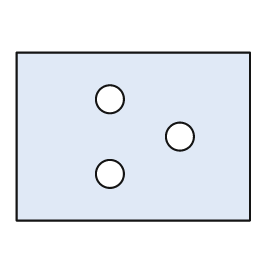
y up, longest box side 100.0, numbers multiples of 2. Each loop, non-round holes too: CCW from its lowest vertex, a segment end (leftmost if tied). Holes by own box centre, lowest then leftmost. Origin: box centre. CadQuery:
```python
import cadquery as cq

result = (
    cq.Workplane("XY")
    .moveTo(-50.0, -36.0)
    .lineTo(50.0, -36.0)
    .lineTo(50.0, 36.0)
    .lineTo(-50.0, 36.0)
    .close()
    .moveTo(-10.0, -16.0)
    .circle(6.0)
    .moveTo(20.0, 0.0)
    .circle(6.0)
    .moveTo(-10.0, 16.0)
    .circle(6.0)
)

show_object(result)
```